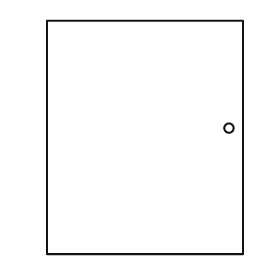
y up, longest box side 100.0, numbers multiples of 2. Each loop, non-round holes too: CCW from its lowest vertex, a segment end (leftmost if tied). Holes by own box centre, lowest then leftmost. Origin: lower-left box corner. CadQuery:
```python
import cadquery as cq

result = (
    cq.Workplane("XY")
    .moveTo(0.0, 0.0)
    .lineTo(84.0, 0.0)
    .lineTo(84.0, 100.0)
    .lineTo(0.0, 100.0)
    .close()
    .moveTo(78.0, 54.0)
    .circle(2.0)
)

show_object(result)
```